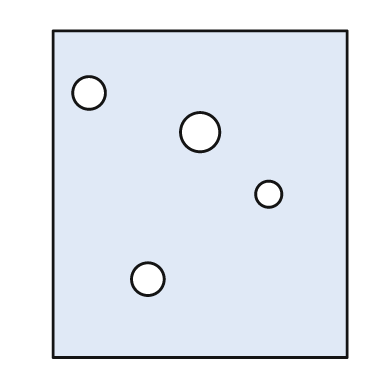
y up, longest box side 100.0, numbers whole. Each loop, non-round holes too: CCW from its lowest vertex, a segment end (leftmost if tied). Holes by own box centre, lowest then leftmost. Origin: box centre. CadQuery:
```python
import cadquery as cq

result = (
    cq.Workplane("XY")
    .moveTo(-45.0, -50.0)
    .lineTo(45.0, -50.0)
    .lineTo(45.0, 50.0)
    .lineTo(-45.0, 50.0)
    .close()
    .moveTo(-16.0, -26.0)
    .circle(5.0)
    .moveTo(21.0, 0.0)
    .circle(4.0)
    .moveTo(0.0, 19.0)
    .circle(6.0)
    .moveTo(-34.0, 31.0)
    .circle(5.0)
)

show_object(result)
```